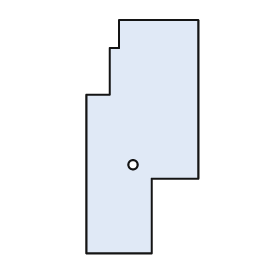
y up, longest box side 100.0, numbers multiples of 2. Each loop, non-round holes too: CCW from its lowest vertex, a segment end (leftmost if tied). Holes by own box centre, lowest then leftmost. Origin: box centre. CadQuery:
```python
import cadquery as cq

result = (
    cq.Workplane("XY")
    .moveTo(-24.0, -50.0)
    .lineTo(4.0, -50.0)
    .lineTo(4.0, -18.0)
    .lineTo(24.0, -18.0)
    .lineTo(24.0, 50.0)
    .lineTo(-10.0, 50.0)
    .lineTo(-10.0, 38.0)
    .lineTo(-14.0, 38.0)
    .lineTo(-14.0, 18.0)
    .lineTo(-24.0, 18.0)
    .close()
    .moveTo(-4.0, -12.0)
    .circle(2.0)
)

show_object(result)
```